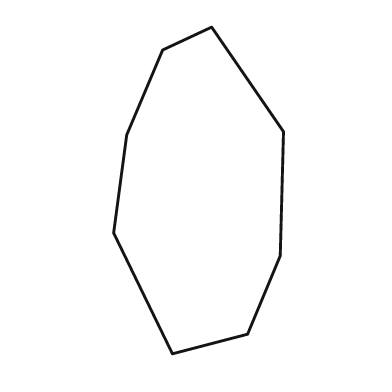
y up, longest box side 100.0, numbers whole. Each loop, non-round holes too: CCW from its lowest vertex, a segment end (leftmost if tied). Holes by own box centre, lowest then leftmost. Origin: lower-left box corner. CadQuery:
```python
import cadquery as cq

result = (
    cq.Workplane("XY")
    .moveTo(18.0, 0.0)
    .lineTo(41.0, 6.0)
    .lineTo(51.0, 30.0)
    .lineTo(52.0, 68.0)
    .lineTo(30.0, 100.0)
    .lineTo(15.0, 93.0)
    .lineTo(4.0, 67.0)
    .lineTo(0.0, 37.0)
    .close()
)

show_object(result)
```